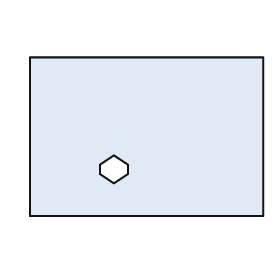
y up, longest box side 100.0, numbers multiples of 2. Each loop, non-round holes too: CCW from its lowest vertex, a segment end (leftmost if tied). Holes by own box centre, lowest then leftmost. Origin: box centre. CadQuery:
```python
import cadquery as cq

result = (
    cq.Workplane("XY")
    .moveTo(-50.0, -34.0)
    .lineTo(50.0, -34.0)
    .lineTo(50.0, 34.0)
    .lineTo(-50.0, 34.0)
    .close()
    .moveTo(-14.0, -20.0)
    .lineTo(-8.0, -16.0)
    .lineTo(-8.0, -12.0)
    .lineTo(-14.0, -8.0)
    .lineTo(-20.0, -12.0)
    .lineTo(-20.0, -16.0)
    .close()
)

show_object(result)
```